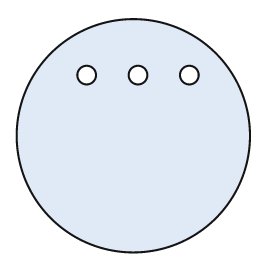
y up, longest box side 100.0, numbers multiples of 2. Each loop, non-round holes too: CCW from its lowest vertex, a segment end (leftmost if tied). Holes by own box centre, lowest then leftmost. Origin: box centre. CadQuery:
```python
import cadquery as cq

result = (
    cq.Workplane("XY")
    .moveTo(0.0, 0.0)
    .circle(50.0)
    .moveTo(-20.0, 26.0)
    .circle(4.0)
    .moveTo(2.0, 26.0)
    .circle(4.0)
    .moveTo(24.0, 26.0)
    .circle(4.0)
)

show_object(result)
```